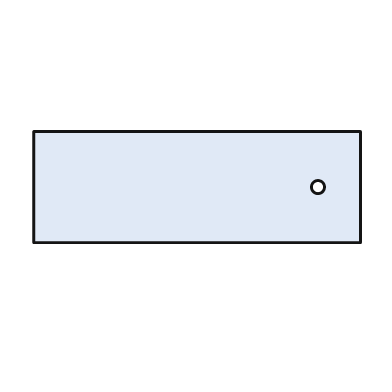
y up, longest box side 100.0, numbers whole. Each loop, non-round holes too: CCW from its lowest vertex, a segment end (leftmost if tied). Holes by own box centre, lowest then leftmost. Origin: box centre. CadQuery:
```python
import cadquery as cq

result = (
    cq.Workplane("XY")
    .moveTo(-50.0, -17.0)
    .lineTo(50.0, -17.0)
    .lineTo(50.0, 17.0)
    .lineTo(-50.0, 17.0)
    .close()
    .moveTo(37.0, 0.0)
    .circle(2.0)
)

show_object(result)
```